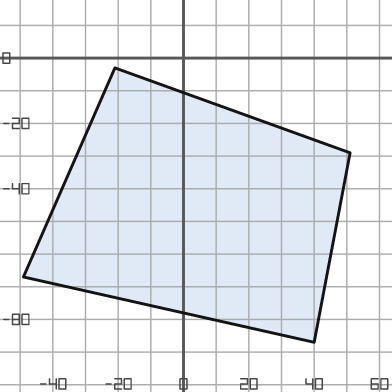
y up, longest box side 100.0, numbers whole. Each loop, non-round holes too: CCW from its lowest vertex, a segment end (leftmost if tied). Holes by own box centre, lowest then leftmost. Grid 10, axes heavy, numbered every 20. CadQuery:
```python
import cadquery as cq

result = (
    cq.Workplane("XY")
    .moveTo(40.0, -87.0)
    .lineTo(51.0, -29.0)
    .lineTo(-21.0, -3.0)
    .lineTo(-49.0, -67.0)
    .close()
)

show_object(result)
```